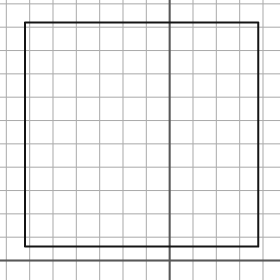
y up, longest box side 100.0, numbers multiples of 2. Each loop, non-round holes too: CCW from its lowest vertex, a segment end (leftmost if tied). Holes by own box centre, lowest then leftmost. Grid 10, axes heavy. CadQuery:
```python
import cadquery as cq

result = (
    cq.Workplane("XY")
    .moveTo(-62.0, 6.0)
    .lineTo(38.0, 6.0)
    .lineTo(38.0, 102.0)
    .lineTo(-62.0, 102.0)
    .close()
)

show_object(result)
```